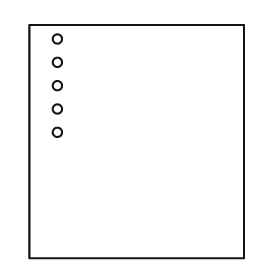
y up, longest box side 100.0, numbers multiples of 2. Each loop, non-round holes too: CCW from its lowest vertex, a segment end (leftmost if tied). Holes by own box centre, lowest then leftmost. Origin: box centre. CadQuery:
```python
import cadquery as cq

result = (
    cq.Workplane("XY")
    .moveTo(-46.0, -50.0)
    .lineTo(46.0, -50.0)
    .lineTo(46.0, 50.0)
    .lineTo(-46.0, 50.0)
    .close()
    .moveTo(-34.0, 4.0)
    .circle(2.0)
    .moveTo(-34.0, 14.0)
    .circle(2.0)
    .moveTo(-34.0, 24.0)
    .circle(2.0)
    .moveTo(-34.0, 34.0)
    .circle(2.0)
    .moveTo(-34.0, 44.0)
    .circle(2.0)
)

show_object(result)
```